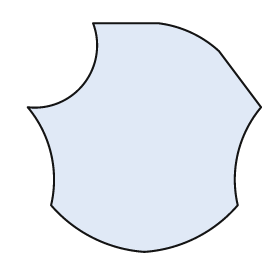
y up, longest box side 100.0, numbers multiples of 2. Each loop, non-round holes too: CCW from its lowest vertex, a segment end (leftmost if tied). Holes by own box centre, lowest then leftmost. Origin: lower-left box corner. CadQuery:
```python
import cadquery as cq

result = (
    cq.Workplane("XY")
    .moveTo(50.0, 0.0)
    .threePointArc((72.0, 6.0), (90.0, 20.0))
    .threePointArc((90.0, 42.0), (100.0, 62.0))
    .lineTo(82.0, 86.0)
    .threePointArc((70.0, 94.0), (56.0, 98.0))
    .lineTo(28.0, 98.0)
    .threePointArc((24.0, 72.0), (0.0, 62.0))
    .threePointArc((10.0, 42.0), (10.0, 20.0))
    .threePointArc((28.0, 6.0), (50.0, 0.0))
    .close()
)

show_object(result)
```